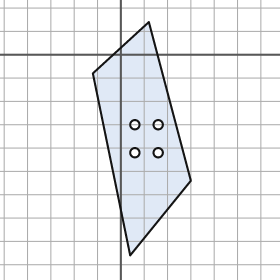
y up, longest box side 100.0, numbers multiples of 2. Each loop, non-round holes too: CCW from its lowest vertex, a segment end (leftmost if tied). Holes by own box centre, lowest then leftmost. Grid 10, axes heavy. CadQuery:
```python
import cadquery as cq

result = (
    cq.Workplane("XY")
    .moveTo(4.0, -86.0)
    .lineTo(30.0, -54.0)
    .lineTo(12.0, 14.0)
    .lineTo(-12.0, -8.0)
    .close()
    .moveTo(6.0, -42.0)
    .circle(2.0)
    .moveTo(16.0, -42.0)
    .circle(2.0)
    .moveTo(6.0, -30.0)
    .circle(2.0)
    .moveTo(16.0, -30.0)
    .circle(2.0)
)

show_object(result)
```